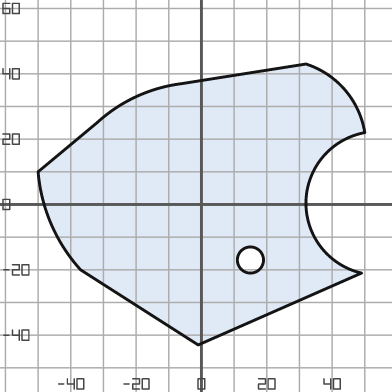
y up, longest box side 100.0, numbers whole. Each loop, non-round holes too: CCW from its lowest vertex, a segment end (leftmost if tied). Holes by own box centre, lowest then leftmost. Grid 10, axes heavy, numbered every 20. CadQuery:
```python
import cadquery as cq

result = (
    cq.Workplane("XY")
    .moveTo(-1.0, -43.0)
    .lineTo(49.0, -21.0)
    .threePointArc((32.0, 1.0), (50.0, 22.0))
    .threePointArc((44.0, 35.0), (32.0, 43.0))
    .lineTo(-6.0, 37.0)
    .threePointArc((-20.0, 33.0), (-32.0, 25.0))
    .lineTo(-50.0, 10.0)
    .threePointArc((-46.0, -6.0), (-37.0, -20.0))
    .close()
    .moveTo(15.0, -17.0)
    .circle(4.0)
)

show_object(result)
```